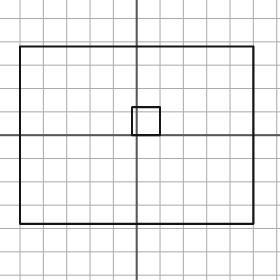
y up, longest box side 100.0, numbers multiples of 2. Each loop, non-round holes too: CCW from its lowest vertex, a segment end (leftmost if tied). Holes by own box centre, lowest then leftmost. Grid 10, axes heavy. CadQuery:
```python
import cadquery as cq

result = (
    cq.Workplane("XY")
    .moveTo(-50.0, -38.0)
    .lineTo(50.0, -38.0)
    .lineTo(50.0, 38.0)
    .lineTo(-50.0, 38.0)
    .close()
    .moveTo(-2.0, 0.0)
    .lineTo(10.0, 0.0)
    .lineTo(10.0, 12.0)
    .lineTo(-2.0, 12.0)
    .close()
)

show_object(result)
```